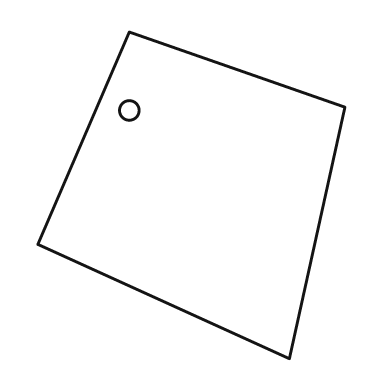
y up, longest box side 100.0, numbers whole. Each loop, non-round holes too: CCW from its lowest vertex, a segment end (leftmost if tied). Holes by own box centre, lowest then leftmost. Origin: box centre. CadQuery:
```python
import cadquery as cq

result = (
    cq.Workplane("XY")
    .moveTo(30.0, -50.0)
    .lineTo(47.0, 27.0)
    .lineTo(-19.0, 50.0)
    .lineTo(-47.0, -15.0)
    .close()
    .moveTo(-19.0, 26.0)
    .circle(3.0)
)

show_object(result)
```